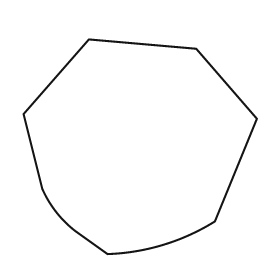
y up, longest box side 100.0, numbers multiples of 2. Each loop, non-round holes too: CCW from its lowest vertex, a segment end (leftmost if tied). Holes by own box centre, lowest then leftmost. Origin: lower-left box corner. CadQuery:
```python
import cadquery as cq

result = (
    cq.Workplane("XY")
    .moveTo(36.0, 0.0)
    .threePointArc((60.0, 4.0), (82.0, 14.0))
    .lineTo(100.0, 58.0)
    .lineTo(74.0, 88.0)
    .lineTo(28.0, 92.0)
    .lineTo(0.0, 60.0)
    .lineTo(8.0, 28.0)
    .threePointArc((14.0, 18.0), (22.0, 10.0))
    .close()
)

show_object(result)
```